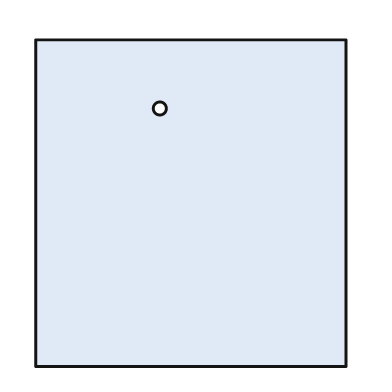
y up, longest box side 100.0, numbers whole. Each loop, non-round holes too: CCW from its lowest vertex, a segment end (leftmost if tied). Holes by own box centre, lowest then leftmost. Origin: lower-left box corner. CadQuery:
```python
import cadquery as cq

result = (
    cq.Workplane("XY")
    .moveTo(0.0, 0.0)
    .lineTo(95.0, 0.0)
    .lineTo(95.0, 100.0)
    .lineTo(0.0, 100.0)
    .close()
    .moveTo(38.0, 79.0)
    .circle(2.0)
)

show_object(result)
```